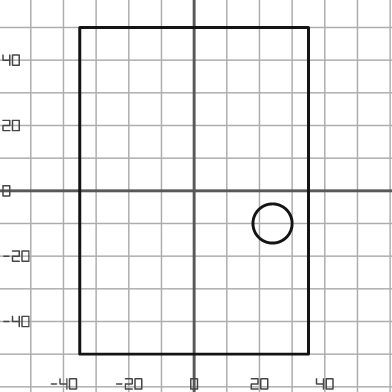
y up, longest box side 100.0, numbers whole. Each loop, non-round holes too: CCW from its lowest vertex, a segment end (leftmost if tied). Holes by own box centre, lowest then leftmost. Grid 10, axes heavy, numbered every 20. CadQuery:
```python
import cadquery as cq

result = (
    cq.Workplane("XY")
    .moveTo(-35.0, -50.0)
    .lineTo(35.0, -50.0)
    .lineTo(35.0, 50.0)
    .lineTo(-35.0, 50.0)
    .close()
    .moveTo(24.0, -10.0)
    .circle(6.0)
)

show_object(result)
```